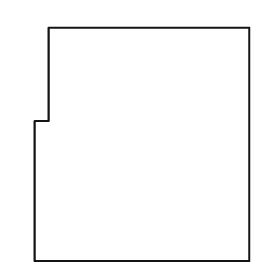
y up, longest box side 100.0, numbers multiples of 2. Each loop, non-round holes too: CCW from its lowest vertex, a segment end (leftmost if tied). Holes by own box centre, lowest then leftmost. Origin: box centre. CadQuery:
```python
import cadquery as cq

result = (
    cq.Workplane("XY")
    .moveTo(-46.0, -50.0)
    .lineTo(46.0, -50.0)
    .lineTo(46.0, 50.0)
    .lineTo(-40.0, 50.0)
    .lineTo(-40.0, 10.0)
    .lineTo(-46.0, 10.0)
    .close()
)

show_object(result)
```